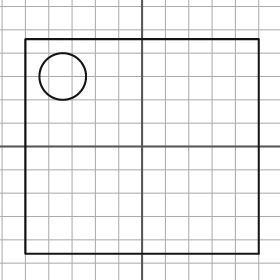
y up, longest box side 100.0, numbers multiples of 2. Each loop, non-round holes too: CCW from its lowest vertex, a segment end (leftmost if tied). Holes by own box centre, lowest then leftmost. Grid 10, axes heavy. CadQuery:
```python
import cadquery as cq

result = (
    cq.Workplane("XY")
    .moveTo(-50.0, -46.0)
    .lineTo(50.0, -46.0)
    .lineTo(50.0, 46.0)
    .lineTo(-50.0, 46.0)
    .close()
    .moveTo(-34.0, 30.0)
    .circle(10.0)
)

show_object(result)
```